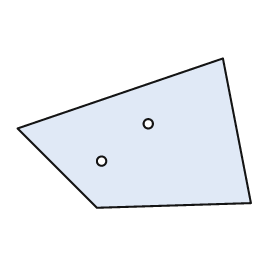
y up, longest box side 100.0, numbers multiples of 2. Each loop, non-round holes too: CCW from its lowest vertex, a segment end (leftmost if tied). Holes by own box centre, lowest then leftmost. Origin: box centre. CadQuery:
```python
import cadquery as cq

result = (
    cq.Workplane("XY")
    .moveTo(-16.0, -32.0)
    .lineTo(50.0, -30.0)
    .lineTo(38.0, 32.0)
    .lineTo(-50.0, 2.0)
    .close()
    .moveTo(-14.0, -12.0)
    .circle(2.0)
    .moveTo(6.0, 4.0)
    .circle(2.0)
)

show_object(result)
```